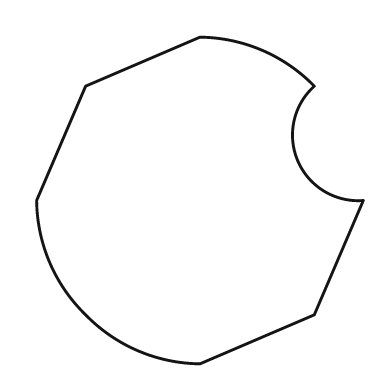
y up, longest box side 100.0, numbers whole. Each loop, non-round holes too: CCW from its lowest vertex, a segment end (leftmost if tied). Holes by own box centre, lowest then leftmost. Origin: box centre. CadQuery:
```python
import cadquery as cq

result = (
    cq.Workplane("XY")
    .moveTo(0.0, -50.0)
    .lineTo(35.0, -35.0)
    .lineTo(50.0, 0.0)
    .threePointArc((30.0, 12.0), (35.0, 35.0))
    .threePointArc((19.0, 46.0), (0.0, 50.0))
    .lineTo(-35.0, 35.0)
    .lineTo(-50.0, 0.0)
    .threePointArc((-46.0, -19.0), (-35.0, -35.0))
    .threePointArc((-19.0, -46.0), (0.0, -50.0))
    .close()
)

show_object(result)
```